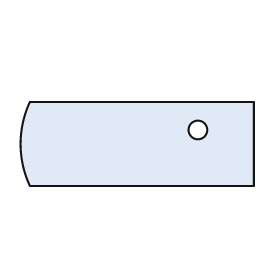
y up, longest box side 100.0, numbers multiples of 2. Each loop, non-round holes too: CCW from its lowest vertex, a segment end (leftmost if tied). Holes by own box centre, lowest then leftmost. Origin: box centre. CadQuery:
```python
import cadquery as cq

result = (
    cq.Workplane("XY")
    .moveTo(-46.0, -18.0)
    .lineTo(50.0, -18.0)
    .lineTo(50.0, 18.0)
    .lineTo(-46.0, 18.0)
    .threePointArc((-50.0, 0.0), (-46.0, -18.0))
    .close()
    .moveTo(26.0, 6.0)
    .circle(4.0)
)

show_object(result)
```